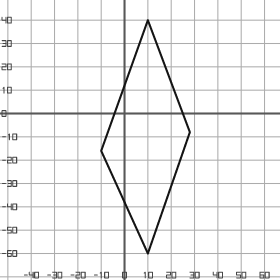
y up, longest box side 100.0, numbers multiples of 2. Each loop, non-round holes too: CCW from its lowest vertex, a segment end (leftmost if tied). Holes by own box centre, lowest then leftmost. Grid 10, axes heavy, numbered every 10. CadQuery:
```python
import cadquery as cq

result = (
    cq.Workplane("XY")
    .moveTo(10.0, -60.0)
    .lineTo(28.0, -8.0)
    .lineTo(10.0, 40.0)
    .lineTo(-10.0, -16.0)
    .close()
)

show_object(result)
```